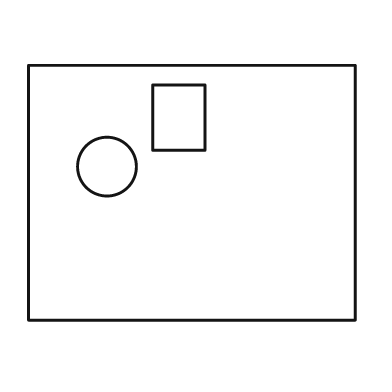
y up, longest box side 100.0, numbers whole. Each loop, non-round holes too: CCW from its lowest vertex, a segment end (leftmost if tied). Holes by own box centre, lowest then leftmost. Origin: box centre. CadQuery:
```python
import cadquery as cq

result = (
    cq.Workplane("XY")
    .moveTo(-50.0, -39.0)
    .lineTo(50.0, -39.0)
    .lineTo(50.0, 39.0)
    .lineTo(-50.0, 39.0)
    .close()
    .moveTo(-26.0, 8.0)
    .circle(9.0)
    .moveTo(-12.0, 13.0)
    .lineTo(4.0, 13.0)
    .lineTo(4.0, 33.0)
    .lineTo(-12.0, 33.0)
    .close()
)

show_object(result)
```